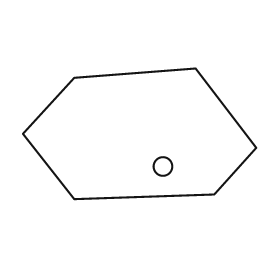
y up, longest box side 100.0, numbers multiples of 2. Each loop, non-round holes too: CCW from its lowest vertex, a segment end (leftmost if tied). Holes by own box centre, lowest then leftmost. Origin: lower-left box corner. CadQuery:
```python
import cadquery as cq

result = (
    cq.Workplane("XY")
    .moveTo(22.0, 0.0)
    .lineTo(82.0, 2.0)
    .lineTo(100.0, 22.0)
    .lineTo(74.0, 56.0)
    .lineTo(22.0, 52.0)
    .lineTo(0.0, 28.0)
    .close()
    .moveTo(60.0, 14.0)
    .circle(4.0)
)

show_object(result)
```